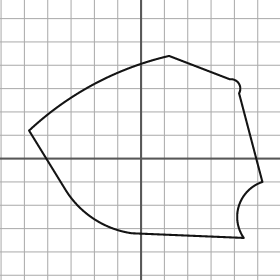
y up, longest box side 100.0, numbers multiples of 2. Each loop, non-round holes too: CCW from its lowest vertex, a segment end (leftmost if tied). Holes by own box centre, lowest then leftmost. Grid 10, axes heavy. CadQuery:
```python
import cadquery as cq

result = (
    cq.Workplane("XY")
    .moveTo(44.0, -34.0)
    .threePointArc((42.0, -20.0), (52.0, -10.0))
    .lineTo(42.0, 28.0)
    .threePointArc((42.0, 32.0), (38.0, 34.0))
    .lineTo(12.0, 44.0)
    .threePointArc((-20.0, 32.0), (-48.0, 12.0))
    .lineTo(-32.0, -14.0)
    .threePointArc((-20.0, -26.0), (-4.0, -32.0))
    .close()
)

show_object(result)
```